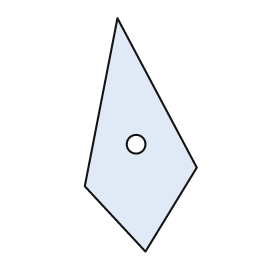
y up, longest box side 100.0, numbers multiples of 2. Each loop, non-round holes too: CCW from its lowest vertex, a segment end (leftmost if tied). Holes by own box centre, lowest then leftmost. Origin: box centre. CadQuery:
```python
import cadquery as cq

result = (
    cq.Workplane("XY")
    .moveTo(2.0, -50.0)
    .lineTo(24.0, -14.0)
    .lineTo(-10.0, 50.0)
    .lineTo(-24.0, -22.0)
    .close()
    .moveTo(-2.0, -4.0)
    .circle(4.0)
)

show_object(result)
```